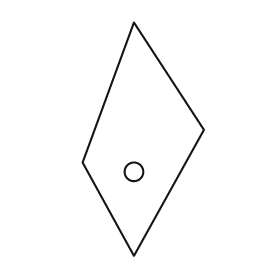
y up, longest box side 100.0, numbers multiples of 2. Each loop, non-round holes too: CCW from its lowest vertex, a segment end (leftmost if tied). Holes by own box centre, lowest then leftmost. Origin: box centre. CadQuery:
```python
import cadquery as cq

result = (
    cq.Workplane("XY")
    .moveTo(-4.0, -50.0)
    .lineTo(26.0, 4.0)
    .lineTo(-4.0, 50.0)
    .lineTo(-26.0, -10.0)
    .close()
    .moveTo(-4.0, -14.0)
    .circle(4.0)
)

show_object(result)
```